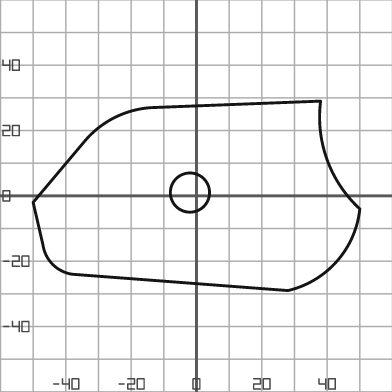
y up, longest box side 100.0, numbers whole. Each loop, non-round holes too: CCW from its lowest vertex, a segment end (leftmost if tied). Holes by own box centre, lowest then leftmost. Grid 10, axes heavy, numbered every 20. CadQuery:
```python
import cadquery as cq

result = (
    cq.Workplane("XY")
    .moveTo(28.0, -29.0)
    .threePointArc((43.0, -20.0), (50.0, -4.0))
    .threePointArc((40.0, 11.0), (38.0, 29.0))
    .lineTo(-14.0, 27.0)
    .threePointArc((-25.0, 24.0), (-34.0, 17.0))
    .lineTo(-50.0, -2.0)
    .lineTo(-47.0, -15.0)
    .threePointArc((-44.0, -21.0), (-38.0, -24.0))
    .close()
    .moveTo(-2.0, 1.0)
    .circle(6.0)
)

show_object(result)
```